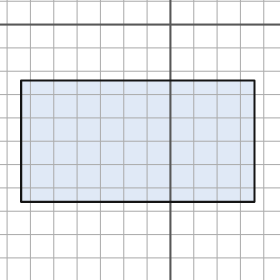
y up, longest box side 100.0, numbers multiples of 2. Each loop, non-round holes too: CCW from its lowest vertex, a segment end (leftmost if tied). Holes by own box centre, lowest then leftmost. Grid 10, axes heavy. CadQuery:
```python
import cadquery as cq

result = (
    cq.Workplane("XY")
    .moveTo(-64.0, -76.0)
    .lineTo(36.0, -76.0)
    .lineTo(36.0, -24.0)
    .lineTo(-64.0, -24.0)
    .close()
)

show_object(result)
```